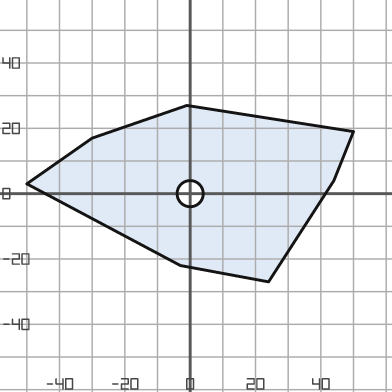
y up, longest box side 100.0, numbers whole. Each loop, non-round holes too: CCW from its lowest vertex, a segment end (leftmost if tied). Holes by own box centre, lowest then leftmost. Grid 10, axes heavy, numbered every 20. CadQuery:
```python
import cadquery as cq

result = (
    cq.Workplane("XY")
    .moveTo(24.0, -27.0)
    .lineTo(44.0, 4.0)
    .lineTo(50.0, 19.0)
    .lineTo(-1.0, 27.0)
    .lineTo(-30.0, 17.0)
    .lineTo(-50.0, 3.0)
    .lineTo(-3.0, -22.0)
    .close()
    .moveTo(0.0, 0.0)
    .circle(4.0)
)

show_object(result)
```